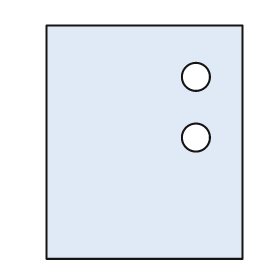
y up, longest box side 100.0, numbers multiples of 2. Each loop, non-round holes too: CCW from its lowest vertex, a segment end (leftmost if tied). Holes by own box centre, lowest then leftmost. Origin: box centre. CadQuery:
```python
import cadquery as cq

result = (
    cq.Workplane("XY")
    .moveTo(-42.0, -50.0)
    .lineTo(42.0, -50.0)
    .lineTo(42.0, 50.0)
    .lineTo(-42.0, 50.0)
    .close()
    .moveTo(22.0, 2.0)
    .circle(6.0)
    .moveTo(22.0, 28.0)
    .circle(6.0)
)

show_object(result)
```